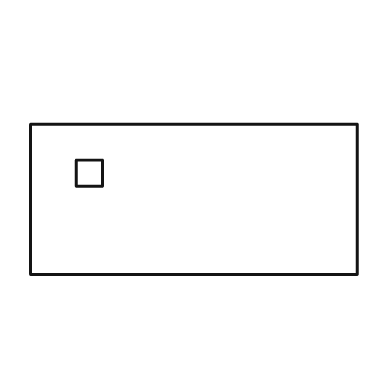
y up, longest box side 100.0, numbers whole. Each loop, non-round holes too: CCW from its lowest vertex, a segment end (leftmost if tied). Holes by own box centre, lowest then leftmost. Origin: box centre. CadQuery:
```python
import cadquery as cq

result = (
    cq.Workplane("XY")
    .moveTo(-50.0, -23.0)
    .lineTo(50.0, -23.0)
    .lineTo(50.0, 23.0)
    .lineTo(-50.0, 23.0)
    .close()
    .moveTo(-36.0, 4.0)
    .lineTo(-28.0, 4.0)
    .lineTo(-28.0, 12.0)
    .lineTo(-36.0, 12.0)
    .close()
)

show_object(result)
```